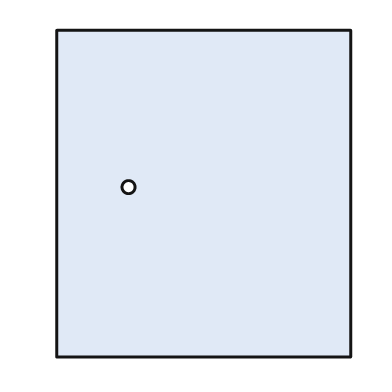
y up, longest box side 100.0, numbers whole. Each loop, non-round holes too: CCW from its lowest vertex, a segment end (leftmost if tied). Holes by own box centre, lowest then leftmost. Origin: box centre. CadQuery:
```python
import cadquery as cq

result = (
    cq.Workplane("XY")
    .moveTo(-45.0, -50.0)
    .lineTo(45.0, -50.0)
    .lineTo(45.0, 50.0)
    .lineTo(-45.0, 50.0)
    .close()
    .moveTo(-23.0, 2.0)
    .circle(2.0)
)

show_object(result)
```